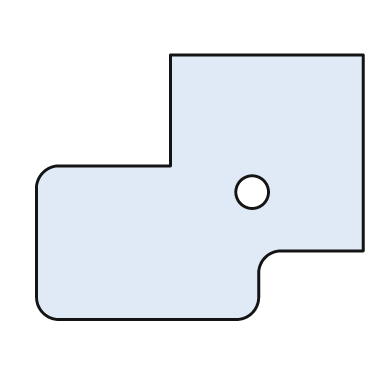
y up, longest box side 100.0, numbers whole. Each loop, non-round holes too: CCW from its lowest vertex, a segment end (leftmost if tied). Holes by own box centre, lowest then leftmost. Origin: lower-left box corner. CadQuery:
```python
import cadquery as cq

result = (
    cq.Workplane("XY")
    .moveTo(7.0, 0.0)
    .lineTo(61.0, 0.0)
    .threePointArc((66.0, 2.0), (68.0, 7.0))
    .lineTo(68.0, 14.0)
    .threePointArc((70.0, 19.0), (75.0, 21.0))
    .lineTo(100.0, 21.0)
    .lineTo(100.0, 81.0)
    .lineTo(41.0, 81.0)
    .lineTo(41.0, 47.0)
    .lineTo(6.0, 47.0)
    .threePointArc((2.0, 45.0), (0.0, 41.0))
    .lineTo(0.0, 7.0)
    .threePointArc((2.0, 2.0), (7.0, 0.0))
    .close()
    .moveTo(66.0, 39.0)
    .circle(5.0)
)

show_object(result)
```